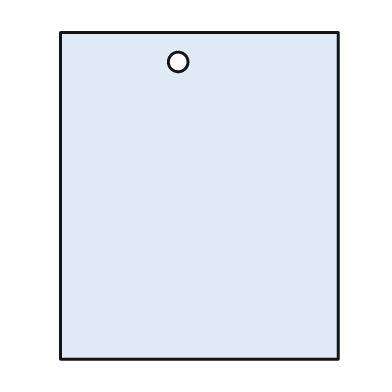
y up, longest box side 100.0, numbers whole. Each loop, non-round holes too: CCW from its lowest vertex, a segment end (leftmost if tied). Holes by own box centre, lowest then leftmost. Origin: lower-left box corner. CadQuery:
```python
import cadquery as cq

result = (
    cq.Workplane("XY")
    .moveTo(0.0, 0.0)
    .lineTo(85.0, 0.0)
    .lineTo(85.0, 100.0)
    .lineTo(0.0, 100.0)
    .close()
    .moveTo(36.0, 91.0)
    .circle(3.0)
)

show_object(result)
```